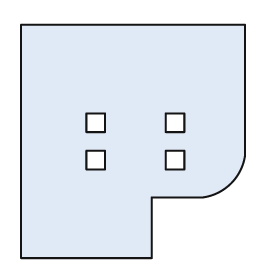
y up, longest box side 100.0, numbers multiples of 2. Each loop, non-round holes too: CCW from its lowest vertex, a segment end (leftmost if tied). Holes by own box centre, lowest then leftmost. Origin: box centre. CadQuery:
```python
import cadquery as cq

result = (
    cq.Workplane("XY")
    .moveTo(-48.0, -50.0)
    .lineTo(8.0, -50.0)
    .lineTo(8.0, -24.0)
    .lineTo(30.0, -24.0)
    .threePointArc((42.0, -18.0), (48.0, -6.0))
    .lineTo(48.0, 50.0)
    .lineTo(-48.0, 50.0)
    .close()
    .moveTo(-20.0, -12.0)
    .lineTo(-12.0, -12.0)
    .lineTo(-12.0, -4.0)
    .lineTo(-20.0, -4.0)
    .close()
    .moveTo(14.0, -12.0)
    .lineTo(22.0, -12.0)
    .lineTo(22.0, -4.0)
    .lineTo(14.0, -4.0)
    .close()
    .moveTo(-20.0, 4.0)
    .lineTo(-12.0, 4.0)
    .lineTo(-12.0, 12.0)
    .lineTo(-20.0, 12.0)
    .close()
    .moveTo(14.0, 4.0)
    .lineTo(22.0, 4.0)
    .lineTo(22.0, 12.0)
    .lineTo(14.0, 12.0)
    .close()
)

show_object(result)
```